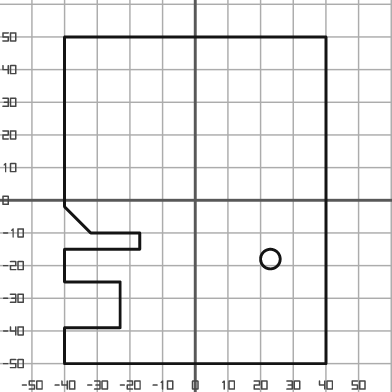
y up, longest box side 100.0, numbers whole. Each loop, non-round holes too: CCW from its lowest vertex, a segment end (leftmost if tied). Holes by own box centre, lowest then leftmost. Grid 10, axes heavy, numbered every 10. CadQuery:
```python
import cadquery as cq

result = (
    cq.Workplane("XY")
    .moveTo(-40.0, -50.0)
    .lineTo(40.0, -50.0)
    .lineTo(40.0, 50.0)
    .lineTo(-40.0, 50.0)
    .lineTo(-40.0, -2.0)
    .lineTo(-32.0, -10.0)
    .lineTo(-17.0, -10.0)
    .lineTo(-17.0, -15.0)
    .lineTo(-40.0, -15.0)
    .lineTo(-40.0, -25.0)
    .lineTo(-23.0, -25.0)
    .lineTo(-23.0, -39.0)
    .lineTo(-40.0, -39.0)
    .close()
    .moveTo(23.0, -18.0)
    .circle(3.0)
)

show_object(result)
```